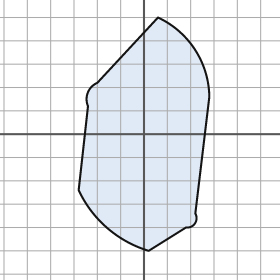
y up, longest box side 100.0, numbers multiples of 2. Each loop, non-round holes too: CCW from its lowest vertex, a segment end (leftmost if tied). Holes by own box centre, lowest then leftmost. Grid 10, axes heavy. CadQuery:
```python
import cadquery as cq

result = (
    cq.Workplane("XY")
    .moveTo(2.0, -50.0)
    .lineTo(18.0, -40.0)
    .threePointArc((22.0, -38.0), (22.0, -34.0))
    .lineTo(28.0, 16.0)
    .threePointArc((22.0, 36.0), (6.0, 50.0))
    .lineTo(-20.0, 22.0)
    .threePointArc((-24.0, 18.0), (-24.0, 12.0))
    .lineTo(-28.0, -24.0)
    .threePointArc((-16.0, -40.0), (2.0, -50.0))
    .close()
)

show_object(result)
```